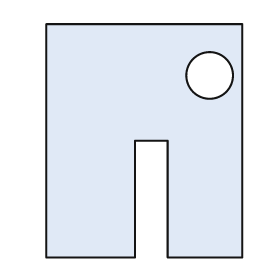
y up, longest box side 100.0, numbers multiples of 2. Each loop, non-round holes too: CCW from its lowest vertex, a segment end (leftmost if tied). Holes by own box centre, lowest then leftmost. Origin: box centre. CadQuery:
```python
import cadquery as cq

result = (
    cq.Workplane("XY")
    .moveTo(-42.0, -50.0)
    .lineTo(-4.0, -50.0)
    .lineTo(-4.0, 0.0)
    .lineTo(10.0, 0.0)
    .lineTo(10.0, -50.0)
    .lineTo(42.0, -50.0)
    .lineTo(42.0, 50.0)
    .lineTo(-42.0, 50.0)
    .close()
    .moveTo(28.0, 28.0)
    .circle(10.0)
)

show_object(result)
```